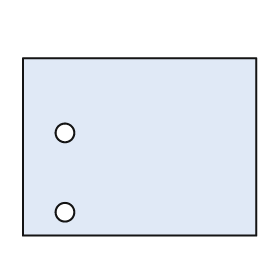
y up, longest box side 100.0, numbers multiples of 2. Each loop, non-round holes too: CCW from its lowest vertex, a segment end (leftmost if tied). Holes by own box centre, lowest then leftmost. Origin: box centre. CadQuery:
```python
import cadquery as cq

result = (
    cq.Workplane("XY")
    .moveTo(-50.0, -38.0)
    .lineTo(50.0, -38.0)
    .lineTo(50.0, 38.0)
    .lineTo(-50.0, 38.0)
    .close()
    .moveTo(-32.0, -28.0)
    .circle(4.0)
    .moveTo(-32.0, 6.0)
    .circle(4.0)
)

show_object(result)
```